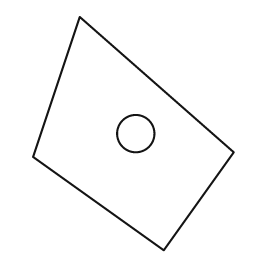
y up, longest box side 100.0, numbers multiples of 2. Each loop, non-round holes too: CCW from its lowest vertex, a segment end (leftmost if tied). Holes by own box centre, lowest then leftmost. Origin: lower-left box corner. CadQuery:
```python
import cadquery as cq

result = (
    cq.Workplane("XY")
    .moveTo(56.0, 0.0)
    .lineTo(86.0, 42.0)
    .lineTo(20.0, 100.0)
    .lineTo(0.0, 40.0)
    .close()
    .moveTo(44.0, 50.0)
    .circle(8.0)
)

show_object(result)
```